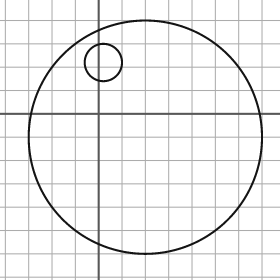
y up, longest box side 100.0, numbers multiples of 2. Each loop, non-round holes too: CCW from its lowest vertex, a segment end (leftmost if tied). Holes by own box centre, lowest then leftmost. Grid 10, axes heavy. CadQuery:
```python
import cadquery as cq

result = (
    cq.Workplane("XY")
    .moveTo(20.0, -10.0)
    .circle(50.0)
    .moveTo(2.0, 22.0)
    .circle(8.0)
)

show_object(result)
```